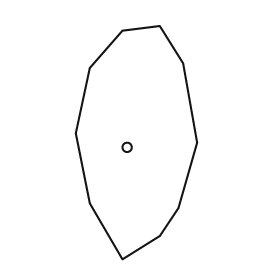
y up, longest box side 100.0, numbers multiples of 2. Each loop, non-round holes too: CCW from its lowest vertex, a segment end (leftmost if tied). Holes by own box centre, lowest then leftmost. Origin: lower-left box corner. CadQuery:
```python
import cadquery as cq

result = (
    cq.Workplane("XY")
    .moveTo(20.0, 0.0)
    .lineTo(36.0, 10.0)
    .lineTo(44.0, 22.0)
    .lineTo(52.0, 50.0)
    .lineTo(46.0, 84.0)
    .lineTo(36.0, 100.0)
    .lineTo(20.0, 98.0)
    .lineTo(6.0, 82.0)
    .lineTo(0.0, 54.0)
    .lineTo(6.0, 24.0)
    .close()
    .moveTo(22.0, 48.0)
    .circle(2.0)
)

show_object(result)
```